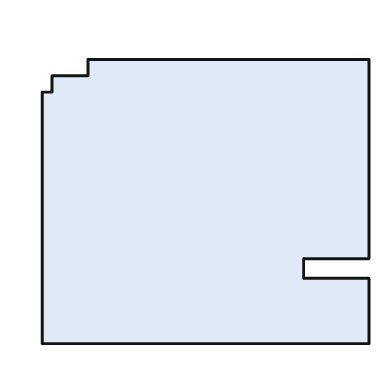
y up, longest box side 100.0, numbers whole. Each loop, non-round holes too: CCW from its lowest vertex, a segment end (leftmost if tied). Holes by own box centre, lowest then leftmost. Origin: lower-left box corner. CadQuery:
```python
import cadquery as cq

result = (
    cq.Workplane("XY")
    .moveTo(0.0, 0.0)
    .lineTo(100.0, 0.0)
    .lineTo(100.0, 20.0)
    .lineTo(80.0, 20.0)
    .lineTo(80.0, 26.0)
    .lineTo(100.0, 26.0)
    .lineTo(100.0, 87.0)
    .lineTo(14.0, 87.0)
    .lineTo(14.0, 82.0)
    .lineTo(3.0, 82.0)
    .lineTo(3.0, 77.0)
    .lineTo(0.0, 77.0)
    .close()
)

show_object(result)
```